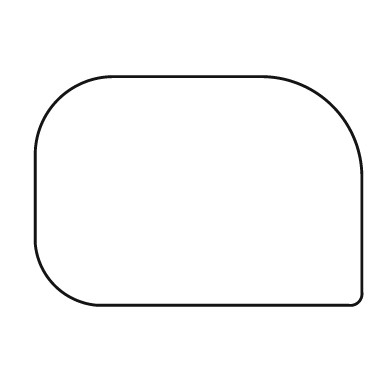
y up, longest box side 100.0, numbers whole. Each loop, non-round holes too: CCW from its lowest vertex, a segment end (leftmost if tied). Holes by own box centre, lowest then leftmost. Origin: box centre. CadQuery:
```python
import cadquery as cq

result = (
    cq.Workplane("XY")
    .moveTo(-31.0, -35.0)
    .lineTo(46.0, -35.0)
    .threePointArc((49.0, -34.0), (50.0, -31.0))
    .lineTo(50.0, 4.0)
    .threePointArc((41.0, 26.0), (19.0, 35.0))
    .lineTo(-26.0, 35.0)
    .threePointArc((-43.0, 28.0), (-50.0, 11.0))
    .lineTo(-50.0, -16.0)
    .threePointArc((-44.0, -29.0), (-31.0, -35.0))
    .close()
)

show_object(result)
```